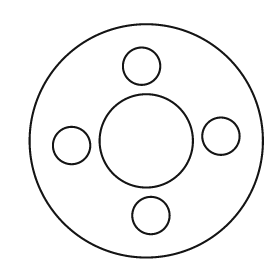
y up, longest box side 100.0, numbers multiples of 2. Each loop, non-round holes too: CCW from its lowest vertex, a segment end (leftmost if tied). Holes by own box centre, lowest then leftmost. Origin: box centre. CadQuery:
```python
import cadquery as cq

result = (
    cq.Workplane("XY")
    .moveTo(0.0, 0.0)
    .circle(50.0)
    .moveTo(2.0, -32.0)
    .circle(8.0)
    .moveTo(-32.0, -2.0)
    .circle(8.0)
    .moveTo(0.0, 0.0)
    .circle(20.0)
    .moveTo(32.0, 2.0)
    .circle(8.0)
    .moveTo(-2.0, 32.0)
    .circle(8.0)
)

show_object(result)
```